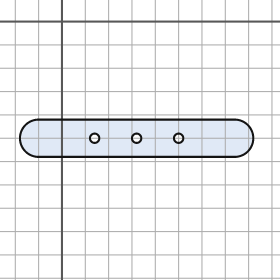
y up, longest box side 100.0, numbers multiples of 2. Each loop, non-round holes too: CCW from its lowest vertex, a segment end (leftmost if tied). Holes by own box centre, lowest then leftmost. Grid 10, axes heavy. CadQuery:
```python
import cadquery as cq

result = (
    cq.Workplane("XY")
    .moveTo(-10.0, -58.0)
    .lineTo(74.0, -58.0)
    .threePointArc((82.0, -50.0), (74.0, -42.0))
    .lineTo(-10.0, -42.0)
    .threePointArc((-18.0, -50.0), (-10.0, -58.0))
    .close()
    .moveTo(14.0, -50.0)
    .circle(2.0)
    .moveTo(32.0, -50.0)
    .circle(2.0)
    .moveTo(50.0, -50.0)
    .circle(2.0)
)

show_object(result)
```